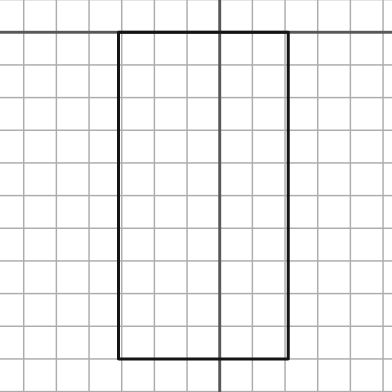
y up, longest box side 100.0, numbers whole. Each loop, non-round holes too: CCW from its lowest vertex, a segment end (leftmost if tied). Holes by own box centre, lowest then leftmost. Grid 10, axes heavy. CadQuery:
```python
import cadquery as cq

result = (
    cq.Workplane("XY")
    .moveTo(-31.0, -100.0)
    .lineTo(21.0, -100.0)
    .lineTo(21.0, 0.0)
    .lineTo(-31.0, 0.0)
    .close()
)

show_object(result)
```